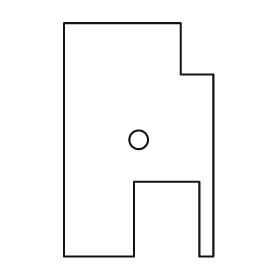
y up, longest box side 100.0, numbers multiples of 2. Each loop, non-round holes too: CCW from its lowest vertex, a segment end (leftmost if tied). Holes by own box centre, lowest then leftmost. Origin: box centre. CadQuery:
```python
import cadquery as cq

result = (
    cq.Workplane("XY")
    .moveTo(-32.0, -50.0)
    .lineTo(-2.0, -50.0)
    .lineTo(-2.0, -18.0)
    .lineTo(26.0, -18.0)
    .lineTo(26.0, -50.0)
    .lineTo(32.0, -50.0)
    .lineTo(32.0, 28.0)
    .lineTo(18.0, 28.0)
    .lineTo(18.0, 50.0)
    .lineTo(-32.0, 50.0)
    .close()
    .moveTo(0.0, 0.0)
    .circle(4.0)
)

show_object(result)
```